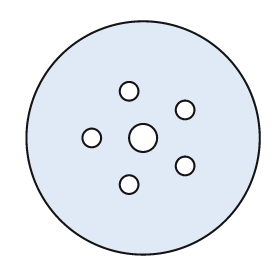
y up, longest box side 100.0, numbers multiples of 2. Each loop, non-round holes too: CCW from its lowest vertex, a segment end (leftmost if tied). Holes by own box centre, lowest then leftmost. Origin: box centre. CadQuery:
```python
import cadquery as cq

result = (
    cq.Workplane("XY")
    .moveTo(0.0, 0.0)
    .circle(50.0)
    .moveTo(-6.0, -20.0)
    .circle(4.0)
    .moveTo(18.0, -12.0)
    .circle(4.0)
    .moveTo(-22.0, 0.0)
    .circle(4.0)
    .moveTo(0.0, 0.0)
    .circle(6.0)
    .moveTo(18.0, 12.0)
    .circle(4.0)
    .moveTo(-6.0, 20.0)
    .circle(4.0)
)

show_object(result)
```